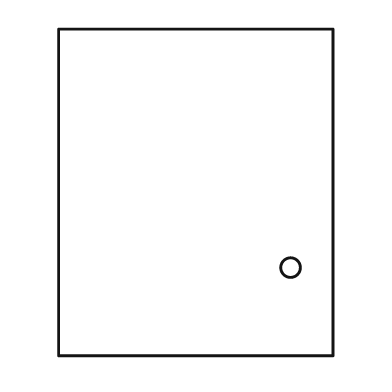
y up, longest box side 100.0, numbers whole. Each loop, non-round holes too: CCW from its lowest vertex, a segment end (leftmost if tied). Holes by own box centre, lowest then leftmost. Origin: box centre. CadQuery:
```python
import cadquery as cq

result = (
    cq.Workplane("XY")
    .moveTo(-42.0, -50.0)
    .lineTo(42.0, -50.0)
    .lineTo(42.0, 50.0)
    .lineTo(-42.0, 50.0)
    .close()
    .moveTo(29.0, -23.0)
    .circle(3.0)
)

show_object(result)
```